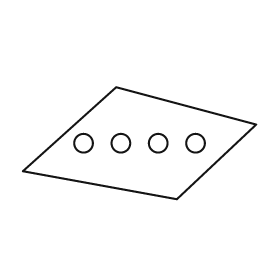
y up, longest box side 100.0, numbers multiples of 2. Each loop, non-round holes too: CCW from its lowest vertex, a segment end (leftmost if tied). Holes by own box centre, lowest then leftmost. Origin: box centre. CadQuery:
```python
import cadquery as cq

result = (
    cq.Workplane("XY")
    .moveTo(16.0, -24.0)
    .lineTo(50.0, 8.0)
    .lineTo(-10.0, 24.0)
    .lineTo(-50.0, -12.0)
    .close()
    .moveTo(-24.0, 0.0)
    .circle(4.0)
    .moveTo(-8.0, 0.0)
    .circle(4.0)
    .moveTo(8.0, 0.0)
    .circle(4.0)
    .moveTo(24.0, 0.0)
    .circle(4.0)
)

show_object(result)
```